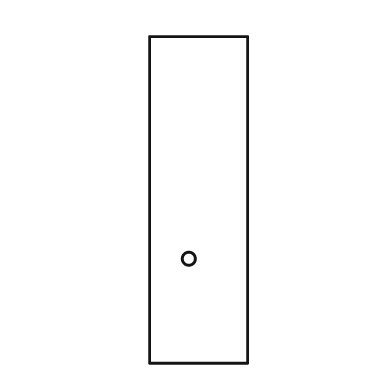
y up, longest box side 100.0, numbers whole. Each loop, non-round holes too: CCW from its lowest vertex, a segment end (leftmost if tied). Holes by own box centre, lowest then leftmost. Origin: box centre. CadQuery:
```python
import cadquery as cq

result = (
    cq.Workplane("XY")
    .moveTo(-15.0, -50.0)
    .lineTo(15.0, -50.0)
    .lineTo(15.0, 50.0)
    .lineTo(-15.0, 50.0)
    .close()
    .moveTo(-3.0, -18.0)
    .circle(2.0)
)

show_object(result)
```